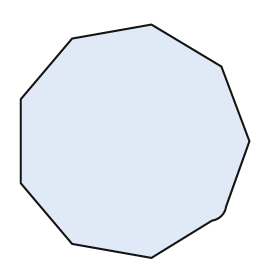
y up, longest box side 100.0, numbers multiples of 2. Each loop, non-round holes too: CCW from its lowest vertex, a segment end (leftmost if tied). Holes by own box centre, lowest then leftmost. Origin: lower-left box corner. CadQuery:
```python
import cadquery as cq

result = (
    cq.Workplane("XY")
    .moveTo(56.0, 0.0)
    .lineTo(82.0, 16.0)
    .threePointArc((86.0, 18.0), (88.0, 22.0))
    .lineTo(98.0, 50.0)
    .lineTo(86.0, 82.0)
    .lineTo(56.0, 100.0)
    .lineTo(22.0, 94.0)
    .lineTo(0.0, 68.0)
    .lineTo(0.0, 32.0)
    .lineTo(22.0, 6.0)
    .close()
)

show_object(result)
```